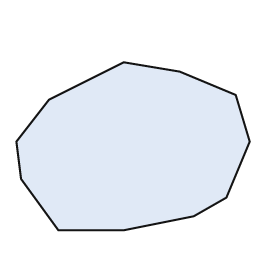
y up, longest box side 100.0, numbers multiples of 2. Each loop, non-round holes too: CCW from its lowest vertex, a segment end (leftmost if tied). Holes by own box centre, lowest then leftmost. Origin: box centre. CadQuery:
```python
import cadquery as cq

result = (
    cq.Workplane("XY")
    .moveTo(-32.0, -36.0)
    .lineTo(-4.0, -36.0)
    .lineTo(26.0, -30.0)
    .lineTo(40.0, -22.0)
    .lineTo(50.0, 2.0)
    .lineTo(44.0, 22.0)
    .lineTo(20.0, 32.0)
    .lineTo(-4.0, 36.0)
    .lineTo(-36.0, 20.0)
    .lineTo(-50.0, 2.0)
    .lineTo(-48.0, -14.0)
    .close()
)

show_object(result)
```